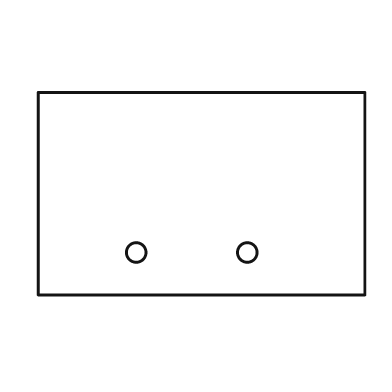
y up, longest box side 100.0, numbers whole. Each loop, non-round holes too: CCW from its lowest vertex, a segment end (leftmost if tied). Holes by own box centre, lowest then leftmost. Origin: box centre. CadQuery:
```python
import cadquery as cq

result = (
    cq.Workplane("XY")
    .moveTo(-50.0, -31.0)
    .lineTo(50.0, -31.0)
    .lineTo(50.0, 31.0)
    .lineTo(-50.0, 31.0)
    .close()
    .moveTo(-20.0, -18.0)
    .circle(3.0)
    .moveTo(14.0, -18.0)
    .circle(3.0)
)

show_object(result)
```